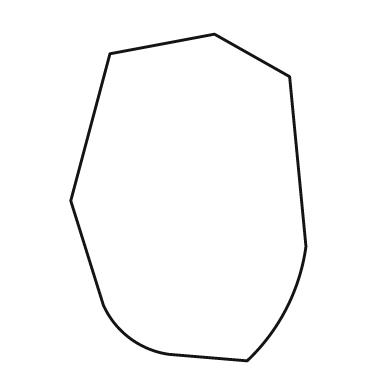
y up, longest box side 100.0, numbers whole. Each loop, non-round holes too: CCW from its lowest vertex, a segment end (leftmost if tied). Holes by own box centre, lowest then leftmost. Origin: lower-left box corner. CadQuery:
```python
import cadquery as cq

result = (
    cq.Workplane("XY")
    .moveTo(54.0, 0.0)
    .threePointArc((66.0, 16.0), (72.0, 35.0))
    .lineTo(67.0, 87.0)
    .lineTo(44.0, 100.0)
    .lineTo(12.0, 94.0)
    .lineTo(0.0, 49.0)
    .lineTo(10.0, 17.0)
    .threePointArc((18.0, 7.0), (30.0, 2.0))
    .close()
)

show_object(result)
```